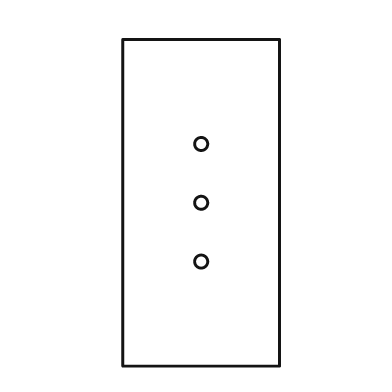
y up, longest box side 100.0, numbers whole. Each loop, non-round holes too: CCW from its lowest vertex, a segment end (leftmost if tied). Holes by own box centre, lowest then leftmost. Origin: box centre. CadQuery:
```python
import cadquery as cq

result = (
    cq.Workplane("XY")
    .moveTo(-24.0, -50.0)
    .lineTo(24.0, -50.0)
    .lineTo(24.0, 50.0)
    .lineTo(-24.0, 50.0)
    .close()
    .moveTo(0.0, -18.0)
    .circle(2.0)
    .moveTo(0.0, 0.0)
    .circle(2.0)
    .moveTo(0.0, 18.0)
    .circle(2.0)
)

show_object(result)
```